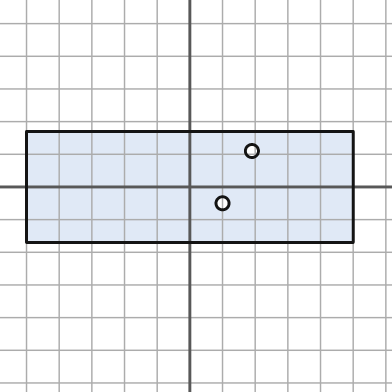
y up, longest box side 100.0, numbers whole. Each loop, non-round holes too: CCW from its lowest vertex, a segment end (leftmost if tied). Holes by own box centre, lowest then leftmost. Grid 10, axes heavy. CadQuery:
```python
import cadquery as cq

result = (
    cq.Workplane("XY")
    .moveTo(-50.0, -17.0)
    .lineTo(50.0, -17.0)
    .lineTo(50.0, 17.0)
    .lineTo(-50.0, 17.0)
    .close()
    .moveTo(10.0, -5.0)
    .circle(2.0)
    .moveTo(19.0, 11.0)
    .circle(2.0)
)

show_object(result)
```